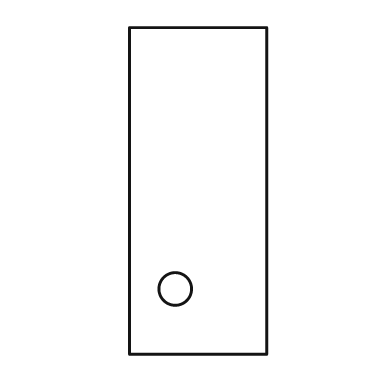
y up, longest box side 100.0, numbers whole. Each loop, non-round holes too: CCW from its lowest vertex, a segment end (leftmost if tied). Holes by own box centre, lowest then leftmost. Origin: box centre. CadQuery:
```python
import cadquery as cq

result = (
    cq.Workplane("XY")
    .moveTo(-21.0, -50.0)
    .lineTo(21.0, -50.0)
    .lineTo(21.0, 50.0)
    .lineTo(-21.0, 50.0)
    .close()
    .moveTo(-7.0, -30.0)
    .circle(5.0)
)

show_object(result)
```